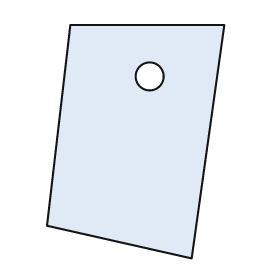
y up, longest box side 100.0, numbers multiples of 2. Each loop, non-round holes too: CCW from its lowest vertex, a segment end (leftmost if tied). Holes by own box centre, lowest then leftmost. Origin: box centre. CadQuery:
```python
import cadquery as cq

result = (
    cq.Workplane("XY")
    .moveTo(24.0, -50.0)
    .lineTo(38.0, 50.0)
    .lineTo(-28.0, 50.0)
    .lineTo(-38.0, -36.0)
    .close()
    .moveTo(6.0, 28.0)
    .circle(6.0)
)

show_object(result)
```